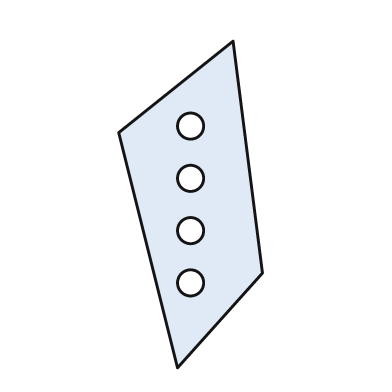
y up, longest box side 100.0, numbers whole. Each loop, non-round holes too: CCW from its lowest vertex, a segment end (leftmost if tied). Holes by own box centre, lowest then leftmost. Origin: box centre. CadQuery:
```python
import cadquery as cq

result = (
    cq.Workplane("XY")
    .moveTo(-4.0, -50.0)
    .lineTo(22.0, -21.0)
    .lineTo(13.0, 50.0)
    .lineTo(-22.0, 22.0)
    .close()
    .moveTo(0.0, -24.0)
    .circle(4.0)
    .moveTo(0.0, -8.0)
    .circle(4.0)
    .moveTo(0.0, 8.0)
    .circle(4.0)
    .moveTo(0.0, 24.0)
    .circle(4.0)
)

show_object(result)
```